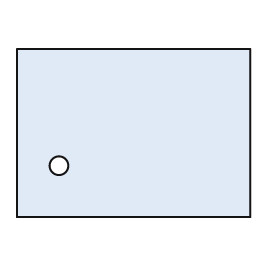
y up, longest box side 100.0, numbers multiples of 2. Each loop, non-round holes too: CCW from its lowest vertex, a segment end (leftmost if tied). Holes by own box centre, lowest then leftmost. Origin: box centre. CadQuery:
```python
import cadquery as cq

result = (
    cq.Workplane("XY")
    .moveTo(-50.0, -36.0)
    .lineTo(50.0, -36.0)
    .lineTo(50.0, 36.0)
    .lineTo(-50.0, 36.0)
    .close()
    .moveTo(-32.0, -14.0)
    .circle(4.0)
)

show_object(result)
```